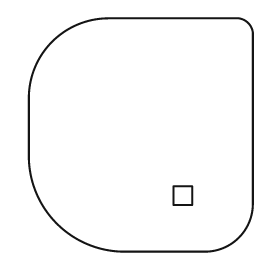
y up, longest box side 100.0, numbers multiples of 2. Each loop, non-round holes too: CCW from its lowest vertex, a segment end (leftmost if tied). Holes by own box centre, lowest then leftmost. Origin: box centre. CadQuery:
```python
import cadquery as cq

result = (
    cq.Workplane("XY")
    .moveTo(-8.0, -50.0)
    .lineTo(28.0, -50.0)
    .threePointArc((42.0, -44.0), (48.0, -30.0))
    .lineTo(48.0, 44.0)
    .threePointArc((46.0, 48.0), (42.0, 50.0))
    .lineTo(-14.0, 50.0)
    .threePointArc((-38.0, 40.0), (-48.0, 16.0))
    .lineTo(-48.0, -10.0)
    .threePointArc((-36.0, -38.0), (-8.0, -50.0))
    .close()
    .moveTo(14.0, -30.0)
    .lineTo(22.0, -30.0)
    .lineTo(22.0, -22.0)
    .lineTo(14.0, -22.0)
    .close()
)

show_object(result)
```